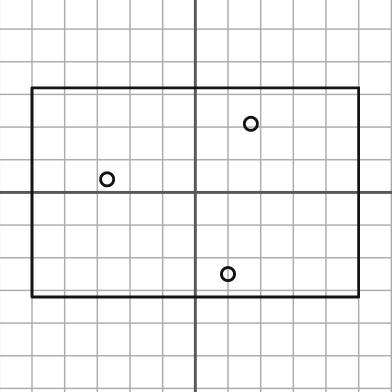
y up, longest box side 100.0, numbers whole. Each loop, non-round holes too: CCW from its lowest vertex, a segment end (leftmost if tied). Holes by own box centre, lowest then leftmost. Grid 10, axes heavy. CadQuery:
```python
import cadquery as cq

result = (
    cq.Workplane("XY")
    .moveTo(-50.0, -32.0)
    .lineTo(50.0, -32.0)
    .lineTo(50.0, 32.0)
    .lineTo(-50.0, 32.0)
    .close()
    .moveTo(10.0, -25.0)
    .circle(2.0)
    .moveTo(-27.0, 4.0)
    .circle(2.0)
    .moveTo(17.0, 21.0)
    .circle(2.0)
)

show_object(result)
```